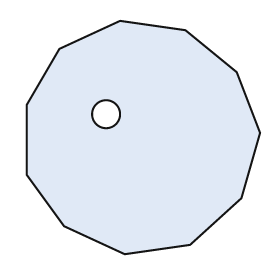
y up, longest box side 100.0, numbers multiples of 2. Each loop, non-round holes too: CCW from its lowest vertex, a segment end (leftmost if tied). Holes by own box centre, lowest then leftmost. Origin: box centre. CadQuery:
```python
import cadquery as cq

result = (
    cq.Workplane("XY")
    .moveTo(-8.0, -50.0)
    .lineTo(20.0, -46.0)
    .lineTo(42.0, -26.0)
    .lineTo(50.0, 2.0)
    .lineTo(40.0, 28.0)
    .lineTo(18.0, 46.0)
    .lineTo(-10.0, 50.0)
    .lineTo(-36.0, 38.0)
    .lineTo(-50.0, 14.0)
    .lineTo(-50.0, -16.0)
    .lineTo(-34.0, -38.0)
    .close()
    .moveTo(-16.0, 10.0)
    .circle(6.0)
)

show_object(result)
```